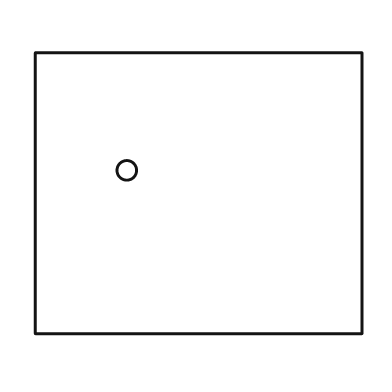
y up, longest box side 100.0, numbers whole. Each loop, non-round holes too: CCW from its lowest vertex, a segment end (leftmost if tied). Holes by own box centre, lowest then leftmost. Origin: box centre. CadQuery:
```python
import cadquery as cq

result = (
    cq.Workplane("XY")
    .moveTo(-50.0, -43.0)
    .lineTo(50.0, -43.0)
    .lineTo(50.0, 43.0)
    .lineTo(-50.0, 43.0)
    .close()
    .moveTo(-22.0, 7.0)
    .circle(3.0)
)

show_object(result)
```